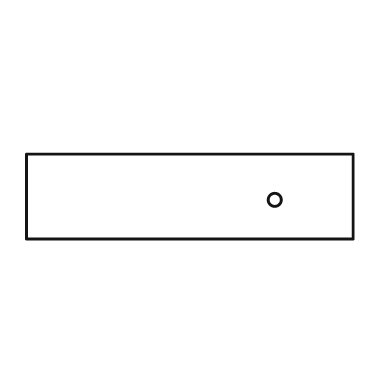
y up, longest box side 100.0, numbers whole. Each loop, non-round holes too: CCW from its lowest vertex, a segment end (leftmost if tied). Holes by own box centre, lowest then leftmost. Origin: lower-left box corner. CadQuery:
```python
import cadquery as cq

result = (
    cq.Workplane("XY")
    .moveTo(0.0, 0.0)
    .lineTo(100.0, 0.0)
    .lineTo(100.0, 26.0)
    .lineTo(0.0, 26.0)
    .close()
    .moveTo(76.0, 12.0)
    .circle(2.0)
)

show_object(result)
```